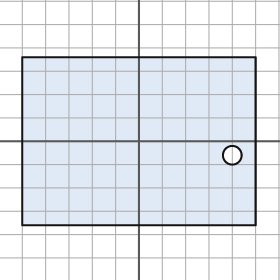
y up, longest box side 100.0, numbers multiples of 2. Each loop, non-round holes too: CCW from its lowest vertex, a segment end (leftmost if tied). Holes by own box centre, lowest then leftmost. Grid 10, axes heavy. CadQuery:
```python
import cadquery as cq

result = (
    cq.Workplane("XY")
    .moveTo(-50.0, -36.0)
    .lineTo(50.0, -36.0)
    .lineTo(50.0, 36.0)
    .lineTo(-50.0, 36.0)
    .close()
    .moveTo(40.0, -6.0)
    .circle(4.0)
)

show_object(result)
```